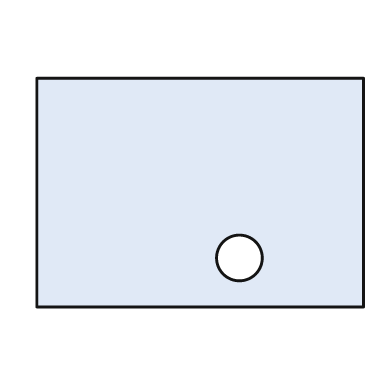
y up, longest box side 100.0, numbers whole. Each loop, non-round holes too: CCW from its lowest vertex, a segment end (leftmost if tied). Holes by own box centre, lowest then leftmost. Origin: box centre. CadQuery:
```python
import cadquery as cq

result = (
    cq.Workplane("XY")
    .moveTo(-50.0, -35.0)
    .lineTo(50.0, -35.0)
    .lineTo(50.0, 35.0)
    .lineTo(-50.0, 35.0)
    .close()
    .moveTo(12.0, -20.0)
    .circle(7.0)
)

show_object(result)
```